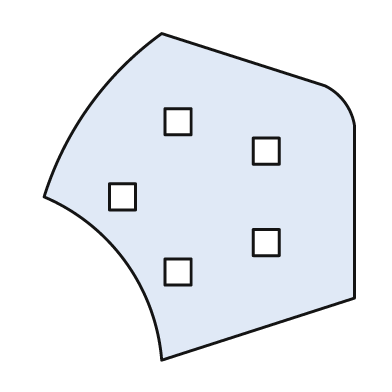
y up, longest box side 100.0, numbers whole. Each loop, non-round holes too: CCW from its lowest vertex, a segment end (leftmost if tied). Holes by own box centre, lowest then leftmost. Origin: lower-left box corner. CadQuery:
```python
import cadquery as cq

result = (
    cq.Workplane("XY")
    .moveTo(36.0, 0.0)
    .lineTo(95.0, 19.0)
    .lineTo(95.0, 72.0)
    .threePointArc((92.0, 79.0), (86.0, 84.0))
    .lineTo(36.0, 100.0)
    .threePointArc((14.0, 78.0), (0.0, 50.0))
    .threePointArc((25.0, 30.0), (36.0, 0.0))
    .close()
    .moveTo(37.0, 23.0)
    .lineTo(45.0, 23.0)
    .lineTo(45.0, 31.0)
    .lineTo(37.0, 31.0)
    .close()
    .moveTo(64.0, 32.0)
    .lineTo(72.0, 32.0)
    .lineTo(72.0, 40.0)
    .lineTo(64.0, 40.0)
    .close()
    .moveTo(20.0, 46.0)
    .lineTo(28.0, 46.0)
    .lineTo(28.0, 54.0)
    .lineTo(20.0, 54.0)
    .close()
    .moveTo(64.0, 60.0)
    .lineTo(72.0, 60.0)
    .lineTo(72.0, 68.0)
    .lineTo(64.0, 68.0)
    .close()
    .moveTo(37.0, 69.0)
    .lineTo(45.0, 69.0)
    .lineTo(45.0, 77.0)
    .lineTo(37.0, 77.0)
    .close()
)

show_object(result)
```